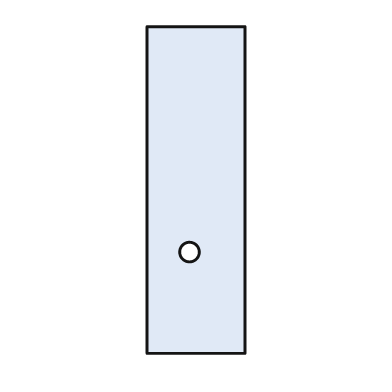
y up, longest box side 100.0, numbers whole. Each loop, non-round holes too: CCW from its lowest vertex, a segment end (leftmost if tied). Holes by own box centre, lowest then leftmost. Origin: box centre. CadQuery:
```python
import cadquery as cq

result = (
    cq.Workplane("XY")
    .moveTo(-15.0, -50.0)
    .lineTo(15.0, -50.0)
    .lineTo(15.0, 50.0)
    .lineTo(-15.0, 50.0)
    .close()
    .moveTo(-2.0, -19.0)
    .circle(3.0)
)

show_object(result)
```